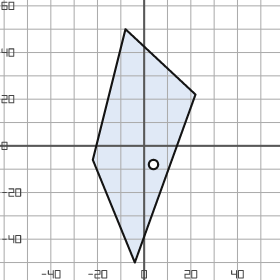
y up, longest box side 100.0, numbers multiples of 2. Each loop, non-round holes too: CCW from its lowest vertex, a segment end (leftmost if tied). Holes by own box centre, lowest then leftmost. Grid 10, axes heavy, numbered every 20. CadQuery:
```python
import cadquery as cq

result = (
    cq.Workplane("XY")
    .moveTo(-4.0, -50.0)
    .lineTo(22.0, 22.0)
    .lineTo(-8.0, 50.0)
    .lineTo(-22.0, -6.0)
    .close()
    .moveTo(4.0, -8.0)
    .circle(2.0)
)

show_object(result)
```